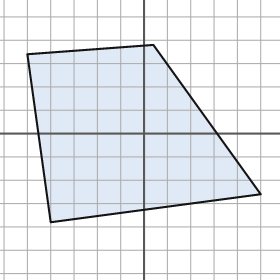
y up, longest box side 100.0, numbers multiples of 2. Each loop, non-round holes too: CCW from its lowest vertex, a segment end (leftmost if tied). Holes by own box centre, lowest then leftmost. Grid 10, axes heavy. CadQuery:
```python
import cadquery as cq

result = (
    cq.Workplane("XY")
    .moveTo(-40.0, -38.0)
    .lineTo(50.0, -26.0)
    .lineTo(4.0, 38.0)
    .lineTo(-50.0, 34.0)
    .close()
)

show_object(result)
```